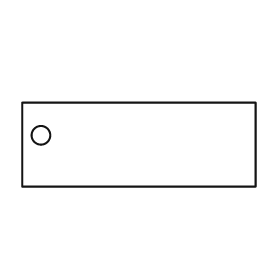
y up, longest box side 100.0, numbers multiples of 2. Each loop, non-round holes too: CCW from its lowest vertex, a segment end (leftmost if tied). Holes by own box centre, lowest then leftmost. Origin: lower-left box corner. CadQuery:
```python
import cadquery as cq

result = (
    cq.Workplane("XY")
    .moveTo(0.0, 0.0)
    .lineTo(100.0, 0.0)
    .lineTo(100.0, 36.0)
    .lineTo(0.0, 36.0)
    .close()
    .moveTo(8.0, 22.0)
    .circle(4.0)
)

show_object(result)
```